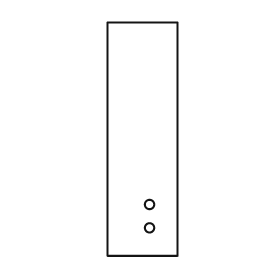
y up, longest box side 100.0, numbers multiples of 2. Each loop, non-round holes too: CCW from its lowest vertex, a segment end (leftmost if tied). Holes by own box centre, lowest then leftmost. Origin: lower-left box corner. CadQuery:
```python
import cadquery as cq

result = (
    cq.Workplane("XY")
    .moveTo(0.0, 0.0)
    .lineTo(30.0, 0.0)
    .lineTo(30.0, 100.0)
    .lineTo(0.0, 100.0)
    .close()
    .moveTo(18.0, 12.0)
    .circle(2.0)
    .moveTo(18.0, 22.0)
    .circle(2.0)
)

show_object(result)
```